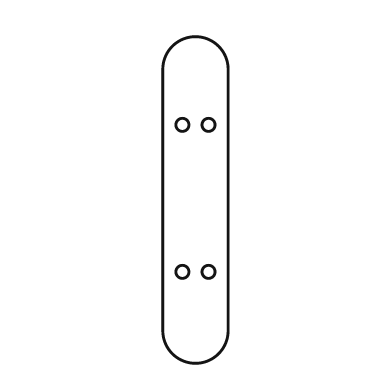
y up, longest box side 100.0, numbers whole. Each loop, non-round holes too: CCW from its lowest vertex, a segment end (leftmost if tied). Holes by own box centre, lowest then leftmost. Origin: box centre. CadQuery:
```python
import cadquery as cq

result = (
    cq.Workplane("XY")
    .moveTo(-10.0, -40.0)
    .threePointArc((0.0, -50.0), (10.0, -40.0))
    .lineTo(10.0, 40.0)
    .threePointArc((0.0, 50.0), (-10.0, 40.0))
    .close()
    .moveTo(-4.0, -22.0)
    .circle(2.0)
    .moveTo(4.0, -22.0)
    .circle(2.0)
    .moveTo(-4.0, 23.0)
    .circle(2.0)
    .moveTo(4.0, 23.0)
    .circle(2.0)
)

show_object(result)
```